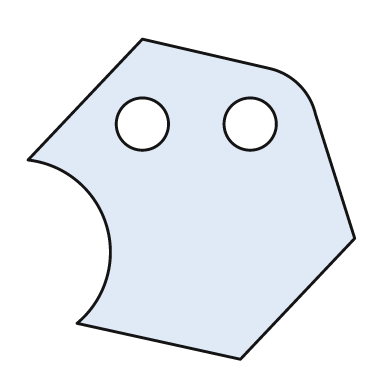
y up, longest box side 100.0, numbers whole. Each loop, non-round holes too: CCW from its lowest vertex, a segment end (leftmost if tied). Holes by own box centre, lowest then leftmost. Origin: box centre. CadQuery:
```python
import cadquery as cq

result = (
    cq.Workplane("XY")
    .moveTo(15.0, -49.0)
    .lineTo(50.0, -12.0)
    .lineTo(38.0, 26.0)
    .threePointArc((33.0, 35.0), (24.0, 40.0))
    .lineTo(-15.0, 49.0)
    .lineTo(-50.0, 12.0)
    .threePointArc((-26.0, -8.0), (-35.0, -38.0))
    .close()
    .moveTo(-15.0, 23.0)
    .circle(8.0)
    .moveTo(18.0, 23.0)
    .circle(8.0)
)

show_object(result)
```